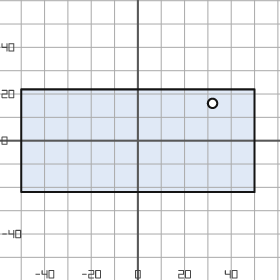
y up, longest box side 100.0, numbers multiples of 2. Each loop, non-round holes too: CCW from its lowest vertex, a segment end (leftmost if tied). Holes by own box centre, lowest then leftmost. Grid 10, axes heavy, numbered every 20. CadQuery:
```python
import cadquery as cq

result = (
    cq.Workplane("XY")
    .moveTo(-50.0, -22.0)
    .lineTo(50.0, -22.0)
    .lineTo(50.0, 22.0)
    .lineTo(-50.0, 22.0)
    .close()
    .moveTo(32.0, 16.0)
    .circle(2.0)
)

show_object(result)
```